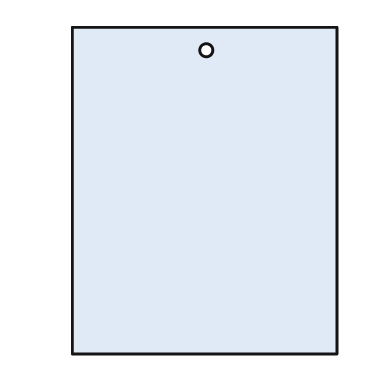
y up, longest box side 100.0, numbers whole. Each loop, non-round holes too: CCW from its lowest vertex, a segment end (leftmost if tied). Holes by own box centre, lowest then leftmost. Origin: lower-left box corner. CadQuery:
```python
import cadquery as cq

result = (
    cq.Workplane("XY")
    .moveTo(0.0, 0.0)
    .lineTo(81.0, 0.0)
    .lineTo(81.0, 100.0)
    .lineTo(0.0, 100.0)
    .close()
    .moveTo(41.0, 93.0)
    .circle(2.0)
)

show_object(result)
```